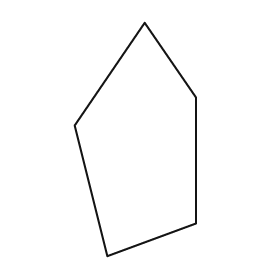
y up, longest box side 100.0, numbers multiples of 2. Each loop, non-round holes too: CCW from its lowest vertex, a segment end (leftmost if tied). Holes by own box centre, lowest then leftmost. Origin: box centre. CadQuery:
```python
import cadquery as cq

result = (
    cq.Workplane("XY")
    .moveTo(-12.0, -50.0)
    .lineTo(26.0, -36.0)
    .lineTo(26.0, 18.0)
    .lineTo(4.0, 50.0)
    .lineTo(-26.0, 6.0)
    .close()
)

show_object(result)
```